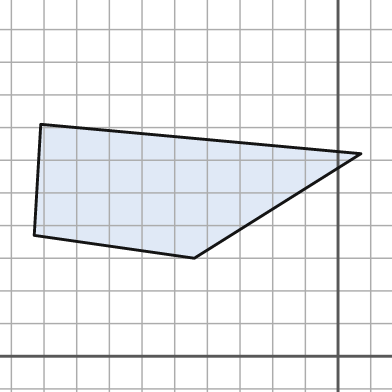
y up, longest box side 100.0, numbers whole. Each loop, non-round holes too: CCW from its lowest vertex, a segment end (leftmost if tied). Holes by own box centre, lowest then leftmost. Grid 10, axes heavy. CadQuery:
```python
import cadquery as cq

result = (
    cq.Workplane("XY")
    .moveTo(-44.0, 30.0)
    .lineTo(7.0, 62.0)
    .lineTo(-91.0, 71.0)
    .lineTo(-93.0, 37.0)
    .close()
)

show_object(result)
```